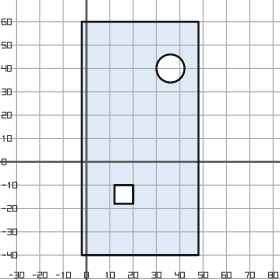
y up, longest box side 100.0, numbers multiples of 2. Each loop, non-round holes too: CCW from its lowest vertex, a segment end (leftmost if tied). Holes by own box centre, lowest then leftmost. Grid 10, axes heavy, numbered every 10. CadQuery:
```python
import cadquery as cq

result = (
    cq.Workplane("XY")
    .moveTo(-2.0, -40.0)
    .lineTo(48.0, -40.0)
    .lineTo(48.0, 60.0)
    .lineTo(-2.0, 60.0)
    .close()
    .moveTo(12.0, -18.0)
    .lineTo(20.0, -18.0)
    .lineTo(20.0, -10.0)
    .lineTo(12.0, -10.0)
    .close()
    .moveTo(36.0, 40.0)
    .circle(6.0)
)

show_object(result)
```